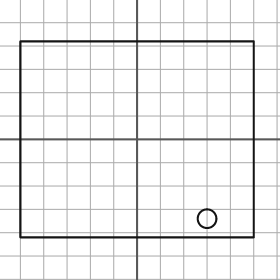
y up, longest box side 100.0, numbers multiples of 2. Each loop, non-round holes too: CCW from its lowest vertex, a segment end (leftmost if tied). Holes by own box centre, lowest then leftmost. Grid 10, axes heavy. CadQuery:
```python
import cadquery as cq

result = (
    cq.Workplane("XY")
    .moveTo(-50.0, -42.0)
    .lineTo(50.0, -42.0)
    .lineTo(50.0, 42.0)
    .lineTo(-50.0, 42.0)
    .close()
    .moveTo(30.0, -34.0)
    .circle(4.0)
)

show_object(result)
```